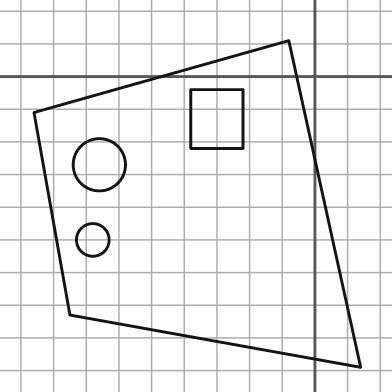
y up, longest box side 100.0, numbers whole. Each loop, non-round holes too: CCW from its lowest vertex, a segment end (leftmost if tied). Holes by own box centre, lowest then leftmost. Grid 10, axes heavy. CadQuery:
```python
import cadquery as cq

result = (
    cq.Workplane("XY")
    .moveTo(14.0, -89.0)
    .lineTo(-8.0, 11.0)
    .lineTo(-86.0, -11.0)
    .lineTo(-75.0, -73.0)
    .close()
    .moveTo(-68.0, -50.0)
    .circle(5.0)
    .moveTo(-66.0, -27.0)
    .circle(8.0)
    .moveTo(-38.0, -22.0)
    .lineTo(-22.0, -22.0)
    .lineTo(-22.0, -4.0)
    .lineTo(-38.0, -4.0)
    .close()
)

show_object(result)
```